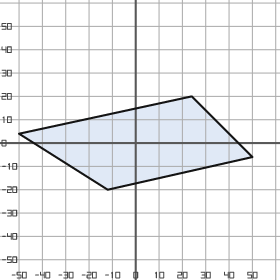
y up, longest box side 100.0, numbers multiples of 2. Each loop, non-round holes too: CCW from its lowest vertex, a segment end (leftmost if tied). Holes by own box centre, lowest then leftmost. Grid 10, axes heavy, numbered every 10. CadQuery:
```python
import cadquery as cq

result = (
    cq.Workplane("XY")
    .moveTo(-12.0, -20.0)
    .lineTo(50.0, -6.0)
    .lineTo(24.0, 20.0)
    .lineTo(-50.0, 4.0)
    .close()
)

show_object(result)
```